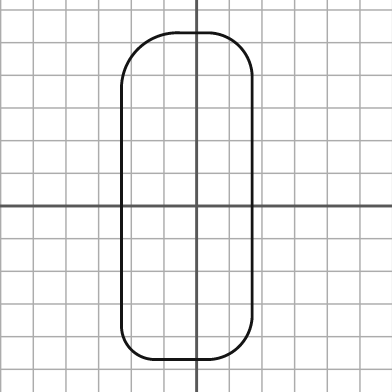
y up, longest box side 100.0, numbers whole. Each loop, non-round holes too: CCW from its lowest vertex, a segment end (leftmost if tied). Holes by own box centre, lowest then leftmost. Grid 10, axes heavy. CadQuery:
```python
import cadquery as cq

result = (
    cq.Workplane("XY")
    .moveTo(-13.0, -47.0)
    .lineTo(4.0, -47.0)
    .threePointArc((13.0, -43.0), (17.0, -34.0))
    .lineTo(17.0, 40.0)
    .threePointArc((13.0, 49.0), (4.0, 53.0))
    .lineTo(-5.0, 53.0)
    .threePointArc((-18.0, 48.0), (-23.0, 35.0))
    .lineTo(-23.0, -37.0)
    .threePointArc((-20.0, -44.0), (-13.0, -47.0))
    .close()
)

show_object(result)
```